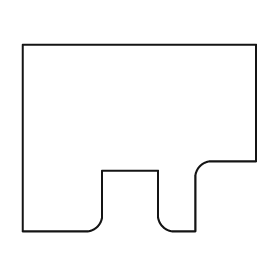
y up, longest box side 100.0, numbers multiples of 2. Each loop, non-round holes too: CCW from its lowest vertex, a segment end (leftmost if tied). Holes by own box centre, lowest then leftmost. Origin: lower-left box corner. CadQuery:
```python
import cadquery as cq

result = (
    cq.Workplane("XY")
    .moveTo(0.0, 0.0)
    .lineTo(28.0, 0.0)
    .threePointArc((32.0, 2.0), (34.0, 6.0))
    .lineTo(34.0, 26.0)
    .lineTo(58.0, 26.0)
    .lineTo(58.0, 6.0)
    .threePointArc((60.0, 2.0), (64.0, 0.0))
    .lineTo(74.0, 0.0)
    .lineTo(74.0, 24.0)
    .threePointArc((76.0, 28.0), (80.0, 30.0))
    .lineTo(100.0, 30.0)
    .lineTo(100.0, 80.0)
    .lineTo(0.0, 80.0)
    .close()
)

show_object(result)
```